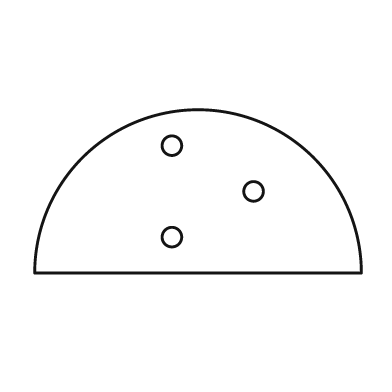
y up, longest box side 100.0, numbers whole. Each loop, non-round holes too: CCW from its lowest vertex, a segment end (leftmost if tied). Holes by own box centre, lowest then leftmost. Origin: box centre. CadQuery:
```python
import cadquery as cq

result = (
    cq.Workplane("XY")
    .moveTo(-50.0, -25.0)
    .lineTo(50.0, -25.0)
    .threePointArc((0.0, 25.0), (-50.0, -25.0))
    .close()
    .moveTo(-8.0, -14.0)
    .circle(3.0)
    .moveTo(17.0, 0.0)
    .circle(3.0)
    .moveTo(-8.0, 14.0)
    .circle(3.0)
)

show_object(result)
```